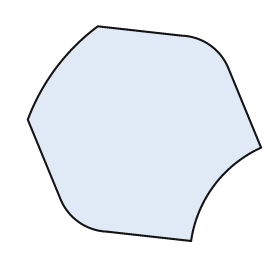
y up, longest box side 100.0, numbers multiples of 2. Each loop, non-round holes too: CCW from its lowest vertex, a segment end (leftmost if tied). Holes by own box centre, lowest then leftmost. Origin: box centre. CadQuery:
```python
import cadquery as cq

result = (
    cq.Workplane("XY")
    .moveTo(20.0, -46.0)
    .threePointArc((30.0, -22.0), (50.0, -6.0))
    .lineTo(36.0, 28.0)
    .threePointArc((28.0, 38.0), (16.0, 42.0))
    .lineTo(-20.0, 46.0)
    .threePointArc((-38.0, 28.0), (-50.0, 6.0))
    .lineTo(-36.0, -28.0)
    .threePointArc((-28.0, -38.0), (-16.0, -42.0))
    .close()
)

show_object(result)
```